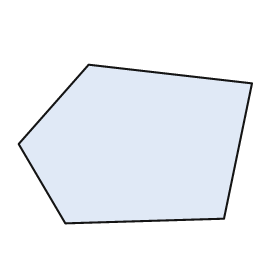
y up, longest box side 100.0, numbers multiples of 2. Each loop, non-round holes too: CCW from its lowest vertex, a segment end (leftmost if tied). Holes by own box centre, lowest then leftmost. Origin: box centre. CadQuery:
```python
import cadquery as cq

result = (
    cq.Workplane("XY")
    .moveTo(-30.0, -34.0)
    .lineTo(38.0, -32.0)
    .lineTo(50.0, 26.0)
    .lineTo(-20.0, 34.0)
    .lineTo(-50.0, 0.0)
    .close()
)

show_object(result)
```